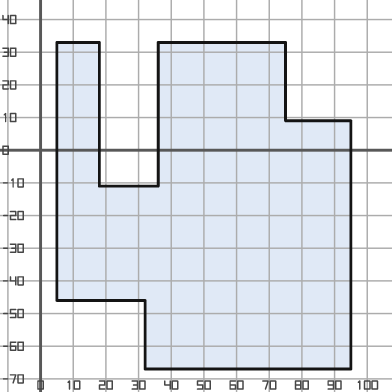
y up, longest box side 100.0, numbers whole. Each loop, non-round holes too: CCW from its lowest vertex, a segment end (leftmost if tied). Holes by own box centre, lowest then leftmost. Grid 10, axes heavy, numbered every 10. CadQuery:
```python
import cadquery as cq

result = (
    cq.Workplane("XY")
    .moveTo(32.0, -67.0)
    .lineTo(95.0, -67.0)
    .lineTo(95.0, 9.0)
    .lineTo(75.0, 9.0)
    .lineTo(75.0, 33.0)
    .lineTo(36.0, 33.0)
    .lineTo(36.0, -11.0)
    .lineTo(18.0, -11.0)
    .lineTo(18.0, 33.0)
    .lineTo(5.0, 33.0)
    .lineTo(5.0, -46.0)
    .lineTo(32.0, -46.0)
    .close()
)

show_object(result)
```